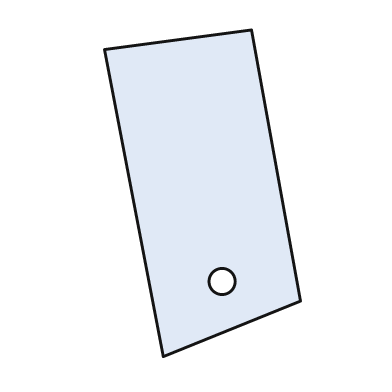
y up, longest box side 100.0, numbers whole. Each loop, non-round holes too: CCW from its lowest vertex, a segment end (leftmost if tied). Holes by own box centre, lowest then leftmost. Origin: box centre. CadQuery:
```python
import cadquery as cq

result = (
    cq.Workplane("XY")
    .moveTo(-12.0, -50.0)
    .lineTo(30.0, -33.0)
    .lineTo(15.0, 50.0)
    .lineTo(-30.0, 44.0)
    .close()
    .moveTo(6.0, -27.0)
    .circle(4.0)
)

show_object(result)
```